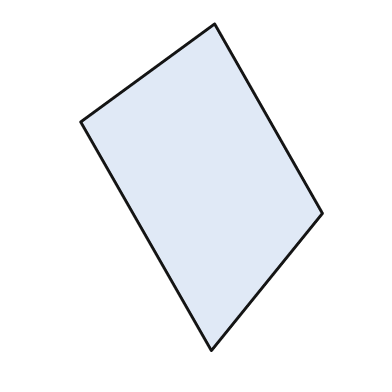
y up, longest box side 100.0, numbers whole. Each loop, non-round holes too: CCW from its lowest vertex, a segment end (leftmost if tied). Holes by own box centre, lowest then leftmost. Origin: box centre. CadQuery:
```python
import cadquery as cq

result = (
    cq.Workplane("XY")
    .moveTo(3.0, -50.0)
    .lineTo(37.0, -8.0)
    .lineTo(4.0, 50.0)
    .lineTo(-37.0, 20.0)
    .close()
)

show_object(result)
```